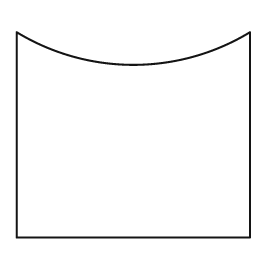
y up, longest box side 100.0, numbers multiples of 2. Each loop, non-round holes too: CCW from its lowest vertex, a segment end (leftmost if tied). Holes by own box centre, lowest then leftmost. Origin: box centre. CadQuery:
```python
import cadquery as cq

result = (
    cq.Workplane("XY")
    .moveTo(-50.0, -44.0)
    .lineTo(50.0, -44.0)
    .lineTo(50.0, 44.0)
    .threePointArc((0.0, 30.0), (-50.0, 44.0))
    .close()
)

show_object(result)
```